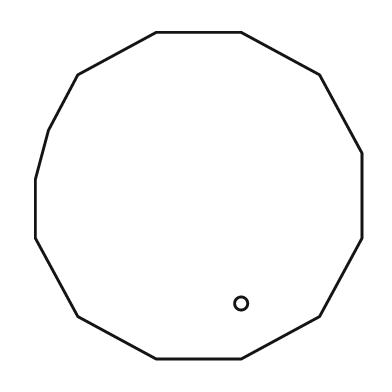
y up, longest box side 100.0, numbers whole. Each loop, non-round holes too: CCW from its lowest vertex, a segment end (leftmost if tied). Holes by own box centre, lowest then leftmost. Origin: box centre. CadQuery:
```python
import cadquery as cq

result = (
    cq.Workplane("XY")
    .moveTo(-13.0, -50.0)
    .lineTo(13.0, -50.0)
    .lineTo(37.0, -37.0)
    .lineTo(50.0, -13.0)
    .lineTo(50.0, 13.0)
    .lineTo(37.0, 37.0)
    .lineTo(13.0, 50.0)
    .lineTo(-13.0, 50.0)
    .lineTo(-37.0, 37.0)
    .lineTo(-46.0, 20.0)
    .lineTo(-50.0, 5.0)
    .lineTo(-50.0, -13.0)
    .lineTo(-37.0, -37.0)
    .close()
    .moveTo(13.0, -33.0)
    .circle(2.0)
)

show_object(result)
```